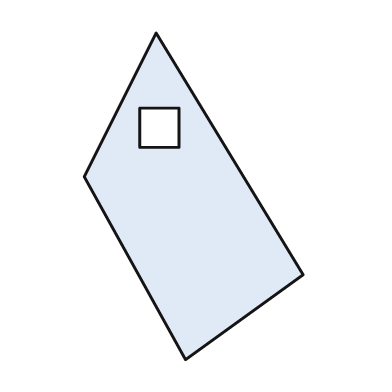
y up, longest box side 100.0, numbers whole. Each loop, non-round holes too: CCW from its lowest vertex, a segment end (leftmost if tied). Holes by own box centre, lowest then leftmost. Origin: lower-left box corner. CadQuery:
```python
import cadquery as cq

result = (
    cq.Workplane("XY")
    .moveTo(31.0, 0.0)
    .lineTo(67.0, 26.0)
    .lineTo(22.0, 100.0)
    .lineTo(0.0, 56.0)
    .close()
    .moveTo(17.0, 65.0)
    .lineTo(29.0, 65.0)
    .lineTo(29.0, 77.0)
    .lineTo(17.0, 77.0)
    .close()
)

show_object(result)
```